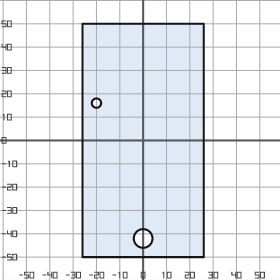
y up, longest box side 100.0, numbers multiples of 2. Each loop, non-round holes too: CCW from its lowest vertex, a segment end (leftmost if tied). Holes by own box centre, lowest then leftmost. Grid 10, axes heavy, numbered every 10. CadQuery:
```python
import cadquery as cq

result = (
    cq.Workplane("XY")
    .moveTo(-26.0, -50.0)
    .lineTo(26.0, -50.0)
    .lineTo(26.0, 50.0)
    .lineTo(-26.0, 50.0)
    .close()
    .moveTo(0.0, -42.0)
    .circle(4.0)
    .moveTo(-20.0, 16.0)
    .circle(2.0)
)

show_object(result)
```